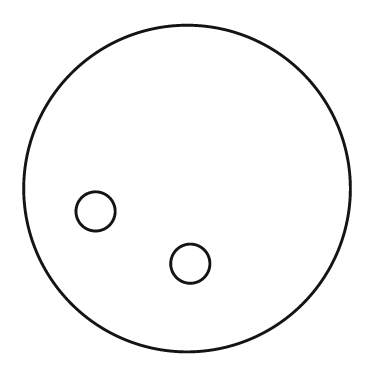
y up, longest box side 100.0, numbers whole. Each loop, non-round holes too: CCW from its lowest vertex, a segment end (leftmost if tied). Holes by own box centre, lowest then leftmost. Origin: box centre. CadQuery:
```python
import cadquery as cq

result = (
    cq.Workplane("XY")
    .moveTo(0.0, 0.0)
    .circle(50.0)
    .moveTo(1.0, -23.0)
    .circle(6.0)
    .moveTo(-28.0, -7.0)
    .circle(6.0)
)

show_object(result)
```